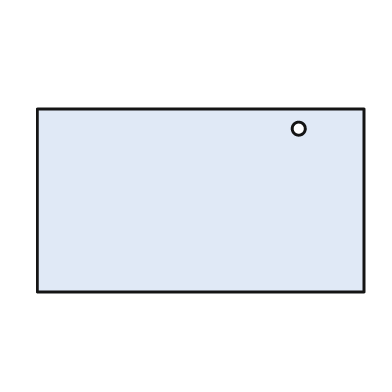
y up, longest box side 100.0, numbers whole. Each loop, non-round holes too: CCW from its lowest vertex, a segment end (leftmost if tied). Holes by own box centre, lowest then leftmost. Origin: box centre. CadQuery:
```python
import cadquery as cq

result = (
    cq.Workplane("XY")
    .moveTo(-50.0, -28.0)
    .lineTo(50.0, -28.0)
    .lineTo(50.0, 28.0)
    .lineTo(-50.0, 28.0)
    .close()
    .moveTo(30.0, 22.0)
    .circle(2.0)
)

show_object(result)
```